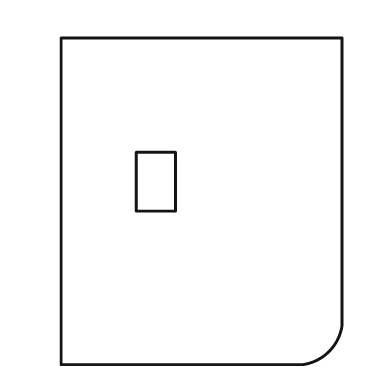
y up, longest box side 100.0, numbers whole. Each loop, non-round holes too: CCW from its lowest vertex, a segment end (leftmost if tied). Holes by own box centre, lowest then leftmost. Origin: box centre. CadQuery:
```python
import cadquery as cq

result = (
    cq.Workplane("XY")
    .moveTo(-43.0, -50.0)
    .lineTo(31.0, -50.0)
    .threePointArc((39.0, -46.0), (43.0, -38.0))
    .lineTo(43.0, 50.0)
    .lineTo(-43.0, 50.0)
    .close()
    .moveTo(-20.0, -3.0)
    .lineTo(-8.0, -3.0)
    .lineTo(-8.0, 15.0)
    .lineTo(-20.0, 15.0)
    .close()
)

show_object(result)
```